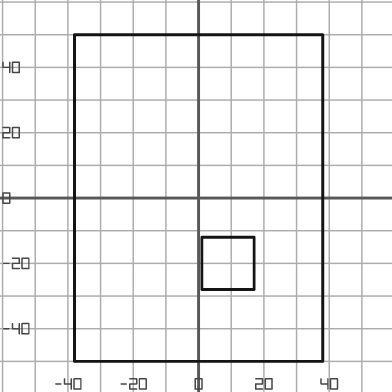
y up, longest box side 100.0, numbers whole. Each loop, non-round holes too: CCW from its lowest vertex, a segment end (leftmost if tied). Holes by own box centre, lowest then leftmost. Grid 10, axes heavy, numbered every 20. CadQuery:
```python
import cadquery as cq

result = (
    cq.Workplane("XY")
    .moveTo(-38.0, -50.0)
    .lineTo(38.0, -50.0)
    .lineTo(38.0, 50.0)
    .lineTo(-38.0, 50.0)
    .close()
    .moveTo(1.0, -28.0)
    .lineTo(17.0, -28.0)
    .lineTo(17.0, -12.0)
    .lineTo(1.0, -12.0)
    .close()
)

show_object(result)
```